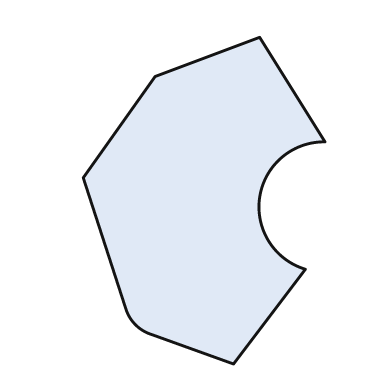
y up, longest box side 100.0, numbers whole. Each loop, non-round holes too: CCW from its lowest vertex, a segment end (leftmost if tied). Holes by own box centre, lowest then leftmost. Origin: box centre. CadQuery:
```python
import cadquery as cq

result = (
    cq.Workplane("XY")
    .moveTo(9.0, -50.0)
    .lineTo(31.0, -21.0)
    .threePointArc((17.0, 1.0), (37.0, 18.0))
    .lineTo(17.0, 50.0)
    .lineTo(-15.0, 38.0)
    .lineTo(-37.0, 7.0)
    .lineTo(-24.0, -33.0)
    .threePointArc((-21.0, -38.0), (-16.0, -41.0))
    .close()
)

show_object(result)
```